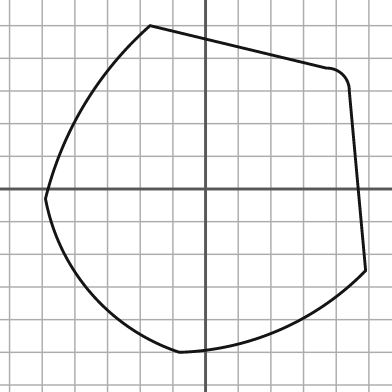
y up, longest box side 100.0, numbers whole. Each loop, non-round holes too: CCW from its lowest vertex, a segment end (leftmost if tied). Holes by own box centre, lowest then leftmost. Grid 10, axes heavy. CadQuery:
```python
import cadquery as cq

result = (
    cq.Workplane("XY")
    .moveTo(-8.0, -50.0)
    .threePointArc((23.0, -43.0), (49.0, -25.0))
    .lineTo(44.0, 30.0)
    .threePointArc((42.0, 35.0), (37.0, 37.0))
    .lineTo(-17.0, 50.0)
    .threePointArc((-37.0, 26.0), (-49.0, -3.0))
    .threePointArc((-35.0, -32.0), (-8.0, -50.0))
    .close()
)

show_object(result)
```